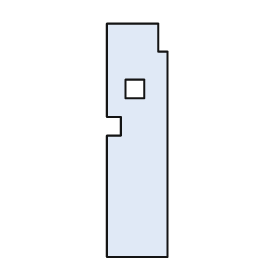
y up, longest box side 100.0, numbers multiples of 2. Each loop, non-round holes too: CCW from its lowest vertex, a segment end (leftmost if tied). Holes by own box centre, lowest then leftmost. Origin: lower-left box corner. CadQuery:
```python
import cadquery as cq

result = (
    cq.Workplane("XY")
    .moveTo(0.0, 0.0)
    .lineTo(26.0, 0.0)
    .lineTo(26.0, 88.0)
    .lineTo(22.0, 88.0)
    .lineTo(22.0, 100.0)
    .lineTo(0.0, 100.0)
    .lineTo(0.0, 60.0)
    .lineTo(6.0, 60.0)
    .lineTo(6.0, 52.0)
    .lineTo(0.0, 52.0)
    .close()
    .moveTo(8.0, 68.0)
    .lineTo(16.0, 68.0)
    .lineTo(16.0, 76.0)
    .lineTo(8.0, 76.0)
    .close()
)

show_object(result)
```